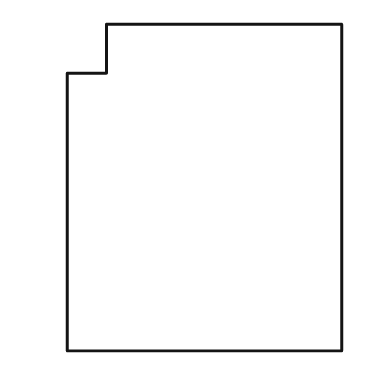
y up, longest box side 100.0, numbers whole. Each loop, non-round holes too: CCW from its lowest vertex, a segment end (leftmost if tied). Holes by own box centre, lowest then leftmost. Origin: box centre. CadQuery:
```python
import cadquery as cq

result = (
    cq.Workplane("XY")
    .moveTo(-42.0, -50.0)
    .lineTo(42.0, -50.0)
    .lineTo(42.0, 50.0)
    .lineTo(-30.0, 50.0)
    .lineTo(-30.0, 35.0)
    .lineTo(-42.0, 35.0)
    .close()
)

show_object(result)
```